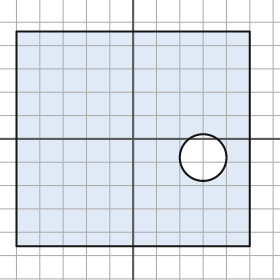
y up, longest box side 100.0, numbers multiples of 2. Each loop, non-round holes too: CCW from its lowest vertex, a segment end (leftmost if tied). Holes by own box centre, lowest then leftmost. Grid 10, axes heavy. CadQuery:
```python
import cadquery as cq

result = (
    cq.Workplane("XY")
    .moveTo(-50.0, -46.0)
    .lineTo(50.0, -46.0)
    .lineTo(50.0, 46.0)
    .lineTo(-50.0, 46.0)
    .close()
    .moveTo(30.0, -8.0)
    .circle(10.0)
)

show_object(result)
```